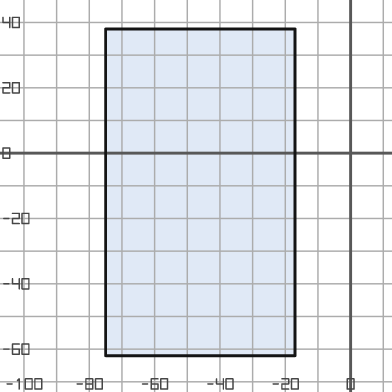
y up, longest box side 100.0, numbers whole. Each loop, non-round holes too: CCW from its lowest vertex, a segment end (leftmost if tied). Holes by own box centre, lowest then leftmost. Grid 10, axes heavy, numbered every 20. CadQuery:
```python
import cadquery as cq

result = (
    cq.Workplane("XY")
    .moveTo(-75.0, -62.0)
    .lineTo(-17.0, -62.0)
    .lineTo(-17.0, 38.0)
    .lineTo(-75.0, 38.0)
    .close()
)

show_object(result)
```